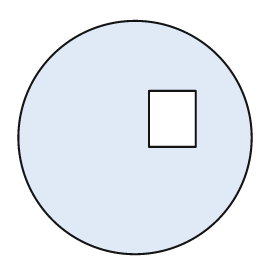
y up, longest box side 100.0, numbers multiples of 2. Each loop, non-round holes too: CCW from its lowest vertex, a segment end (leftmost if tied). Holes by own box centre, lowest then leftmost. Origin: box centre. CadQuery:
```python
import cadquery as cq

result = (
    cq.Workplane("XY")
    .moveTo(0.0, 0.0)
    .circle(50.0)
    .moveTo(6.0, -4.0)
    .lineTo(26.0, -4.0)
    .lineTo(26.0, 20.0)
    .lineTo(6.0, 20.0)
    .close()
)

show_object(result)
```